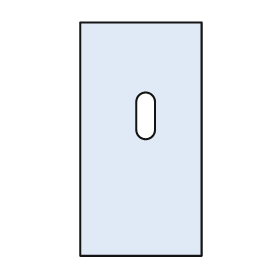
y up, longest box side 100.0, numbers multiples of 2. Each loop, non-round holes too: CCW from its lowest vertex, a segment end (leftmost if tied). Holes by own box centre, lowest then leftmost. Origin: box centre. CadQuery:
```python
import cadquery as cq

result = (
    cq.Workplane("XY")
    .moveTo(-26.0, -50.0)
    .lineTo(26.0, -50.0)
    .lineTo(26.0, 50.0)
    .lineTo(-26.0, 50.0)
    .close()
    .moveTo(-2.0, 4.0)
    .threePointArc((2.0, 0.0), (6.0, 4.0))
    .lineTo(6.0, 16.0)
    .threePointArc((2.0, 20.0), (-2.0, 16.0))
    .close()
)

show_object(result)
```